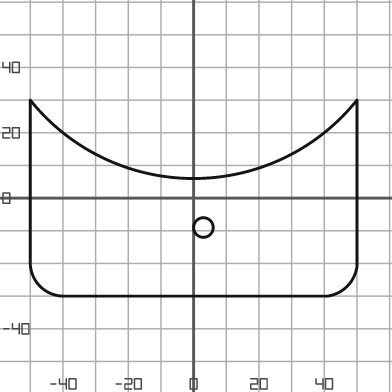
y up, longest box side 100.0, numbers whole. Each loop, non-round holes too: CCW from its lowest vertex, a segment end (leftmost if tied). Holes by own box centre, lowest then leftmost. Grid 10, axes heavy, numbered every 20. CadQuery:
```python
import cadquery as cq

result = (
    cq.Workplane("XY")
    .moveTo(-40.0, -30.0)
    .lineTo(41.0, -30.0)
    .threePointArc((47.0, -27.0), (50.0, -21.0))
    .lineTo(50.0, 30.0)
    .threePointArc((0.0, 6.0), (-50.0, 30.0))
    .lineTo(-50.0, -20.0)
    .threePointArc((-47.0, -27.0), (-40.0, -30.0))
    .close()
    .moveTo(3.0, -9.0)
    .circle(3.0)
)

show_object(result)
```